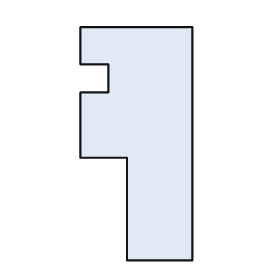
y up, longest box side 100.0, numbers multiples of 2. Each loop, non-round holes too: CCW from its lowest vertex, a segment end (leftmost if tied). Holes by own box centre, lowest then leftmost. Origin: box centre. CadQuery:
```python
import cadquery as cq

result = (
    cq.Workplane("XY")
    .moveTo(-4.0, -50.0)
    .lineTo(24.0, -50.0)
    .lineTo(24.0, 50.0)
    .lineTo(-24.0, 50.0)
    .lineTo(-24.0, 34.0)
    .lineTo(-12.0, 34.0)
    .lineTo(-12.0, 22.0)
    .lineTo(-24.0, 22.0)
    .lineTo(-24.0, -6.0)
    .lineTo(-4.0, -6.0)
    .close()
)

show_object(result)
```